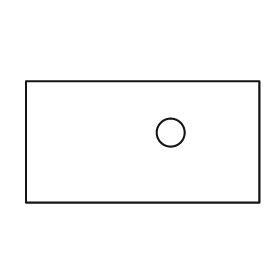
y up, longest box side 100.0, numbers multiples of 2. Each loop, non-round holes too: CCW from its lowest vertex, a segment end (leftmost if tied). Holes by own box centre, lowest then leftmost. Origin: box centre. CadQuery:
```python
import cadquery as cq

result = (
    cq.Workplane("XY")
    .moveTo(-50.0, -26.0)
    .lineTo(50.0, -26.0)
    .lineTo(50.0, 26.0)
    .lineTo(-50.0, 26.0)
    .close()
    .moveTo(12.0, 4.0)
    .circle(6.0)
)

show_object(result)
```